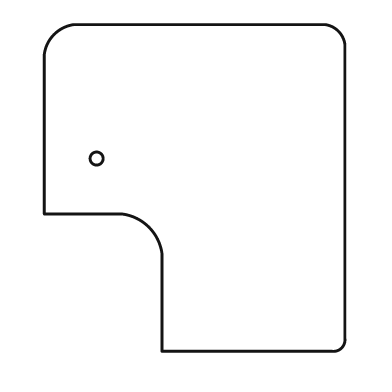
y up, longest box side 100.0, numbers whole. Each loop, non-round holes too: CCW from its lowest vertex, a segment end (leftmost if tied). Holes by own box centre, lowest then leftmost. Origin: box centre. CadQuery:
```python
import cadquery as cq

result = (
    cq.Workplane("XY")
    .moveTo(-10.0, -50.0)
    .lineTo(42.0, -50.0)
    .threePointArc((45.0, -49.0), (46.0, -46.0))
    .lineTo(46.0, 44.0)
    .threePointArc((44.0, 48.0), (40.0, 50.0))
    .lineTo(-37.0, 50.0)
    .threePointArc((-43.0, 47.0), (-46.0, 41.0))
    .lineTo(-46.0, -8.0)
    .lineTo(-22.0, -8.0)
    .threePointArc((-14.0, -12.0), (-10.0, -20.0))
    .close()
    .moveTo(-30.0, 9.0)
    .circle(2.0)
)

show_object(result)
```